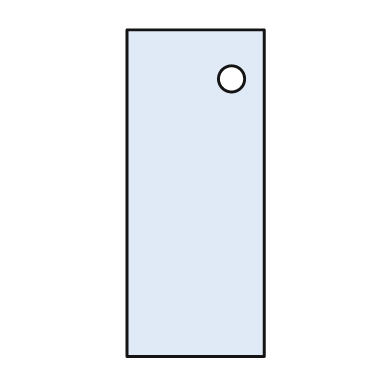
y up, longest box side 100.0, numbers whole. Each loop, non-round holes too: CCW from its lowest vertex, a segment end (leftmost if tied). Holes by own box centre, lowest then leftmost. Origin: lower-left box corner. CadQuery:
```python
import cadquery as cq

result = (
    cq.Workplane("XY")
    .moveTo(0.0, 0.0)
    .lineTo(42.0, 0.0)
    .lineTo(42.0, 100.0)
    .lineTo(0.0, 100.0)
    .close()
    .moveTo(32.0, 85.0)
    .circle(4.0)
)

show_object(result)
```